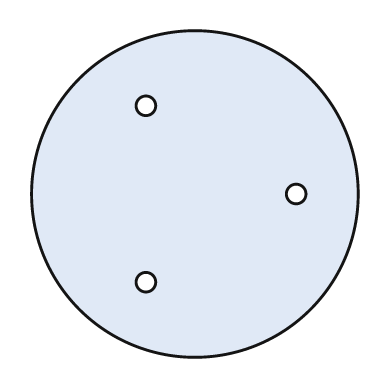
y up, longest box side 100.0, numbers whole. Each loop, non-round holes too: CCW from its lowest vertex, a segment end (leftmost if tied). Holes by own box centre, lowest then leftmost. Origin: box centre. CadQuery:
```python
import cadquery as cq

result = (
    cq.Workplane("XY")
    .moveTo(0.0, 0.0)
    .circle(50.0)
    .moveTo(-15.0, -27.0)
    .circle(3.0)
    .moveTo(31.0, 0.0)
    .circle(3.0)
    .moveTo(-15.0, 27.0)
    .circle(3.0)
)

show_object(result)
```